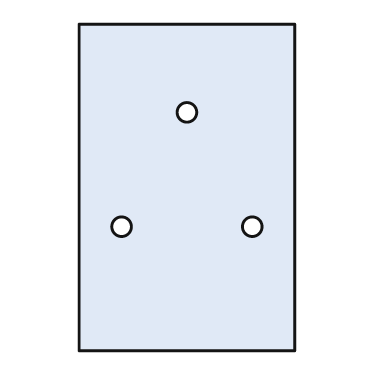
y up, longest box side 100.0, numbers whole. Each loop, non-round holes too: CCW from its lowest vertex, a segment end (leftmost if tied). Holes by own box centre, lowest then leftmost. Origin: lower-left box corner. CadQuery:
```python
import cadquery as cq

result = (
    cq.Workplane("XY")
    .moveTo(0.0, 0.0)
    .lineTo(66.0, 0.0)
    .lineTo(66.0, 100.0)
    .lineTo(0.0, 100.0)
    .close()
    .moveTo(13.0, 38.0)
    .circle(3.0)
    .moveTo(53.0, 38.0)
    .circle(3.0)
    .moveTo(33.0, 73.0)
    .circle(3.0)
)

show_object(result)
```